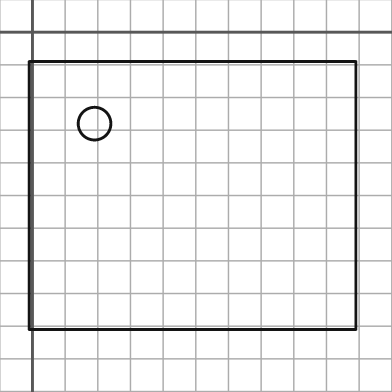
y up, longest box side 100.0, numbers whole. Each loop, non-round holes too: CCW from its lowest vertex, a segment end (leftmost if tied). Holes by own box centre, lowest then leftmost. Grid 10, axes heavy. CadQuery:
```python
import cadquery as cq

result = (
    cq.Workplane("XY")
    .moveTo(-1.0, -91.0)
    .lineTo(99.0, -91.0)
    .lineTo(99.0, -9.0)
    .lineTo(-1.0, -9.0)
    .close()
    .moveTo(19.0, -28.0)
    .circle(5.0)
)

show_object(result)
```